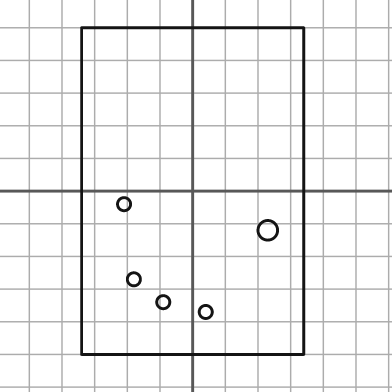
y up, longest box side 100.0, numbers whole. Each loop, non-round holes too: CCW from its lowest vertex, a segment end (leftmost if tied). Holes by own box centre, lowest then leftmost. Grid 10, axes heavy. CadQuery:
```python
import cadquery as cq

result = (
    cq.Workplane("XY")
    .moveTo(-34.0, -50.0)
    .lineTo(34.0, -50.0)
    .lineTo(34.0, 50.0)
    .lineTo(-34.0, 50.0)
    .close()
    .moveTo(4.0, -37.0)
    .circle(2.0)
    .moveTo(-9.0, -34.0)
    .circle(2.0)
    .moveTo(-18.0, -27.0)
    .circle(2.0)
    .moveTo(23.0, -12.0)
    .circle(3.0)
    .moveTo(-21.0, -4.0)
    .circle(2.0)
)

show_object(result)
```